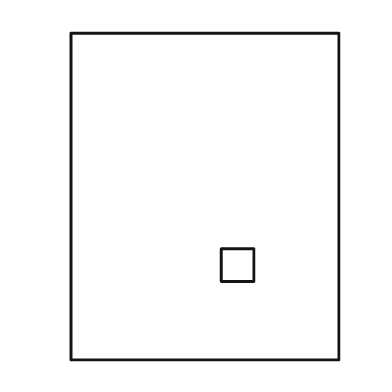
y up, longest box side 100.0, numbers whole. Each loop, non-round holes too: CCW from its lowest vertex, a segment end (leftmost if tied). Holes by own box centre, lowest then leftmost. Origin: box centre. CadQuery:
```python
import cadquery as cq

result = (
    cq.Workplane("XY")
    .moveTo(-41.0, -50.0)
    .lineTo(41.0, -50.0)
    .lineTo(41.0, 50.0)
    .lineTo(-41.0, 50.0)
    .close()
    .moveTo(5.0, -26.0)
    .lineTo(15.0, -26.0)
    .lineTo(15.0, -16.0)
    .lineTo(5.0, -16.0)
    .close()
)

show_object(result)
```